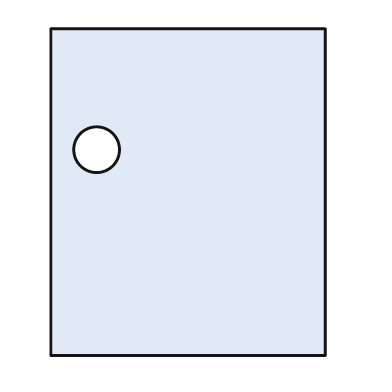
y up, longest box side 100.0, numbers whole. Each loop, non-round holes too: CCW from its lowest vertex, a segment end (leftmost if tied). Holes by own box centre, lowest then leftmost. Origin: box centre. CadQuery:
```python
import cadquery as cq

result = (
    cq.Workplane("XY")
    .moveTo(-42.0, -50.0)
    .lineTo(42.0, -50.0)
    .lineTo(42.0, 50.0)
    .lineTo(-42.0, 50.0)
    .close()
    .moveTo(-28.0, 13.0)
    .circle(7.0)
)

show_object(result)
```